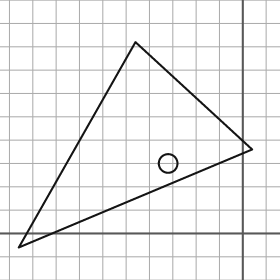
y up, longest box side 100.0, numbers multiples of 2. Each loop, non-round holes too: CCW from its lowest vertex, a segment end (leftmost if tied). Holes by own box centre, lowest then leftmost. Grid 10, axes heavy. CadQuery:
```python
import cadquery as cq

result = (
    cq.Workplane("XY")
    .moveTo(-96.0, -6.0)
    .lineTo(4.0, 36.0)
    .lineTo(-46.0, 82.0)
    .close()
    .moveTo(-32.0, 30.0)
    .circle(4.0)
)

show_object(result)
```